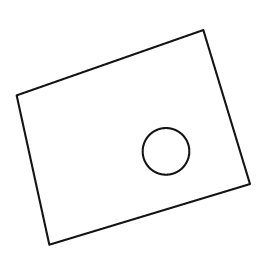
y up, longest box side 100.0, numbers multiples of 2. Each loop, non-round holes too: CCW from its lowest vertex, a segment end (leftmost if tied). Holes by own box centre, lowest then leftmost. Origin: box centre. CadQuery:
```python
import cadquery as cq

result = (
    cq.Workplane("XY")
    .moveTo(-36.0, -46.0)
    .lineTo(50.0, -20.0)
    .lineTo(30.0, 46.0)
    .lineTo(-50.0, 18.0)
    .close()
    .moveTo(14.0, -6.0)
    .circle(10.0)
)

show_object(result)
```